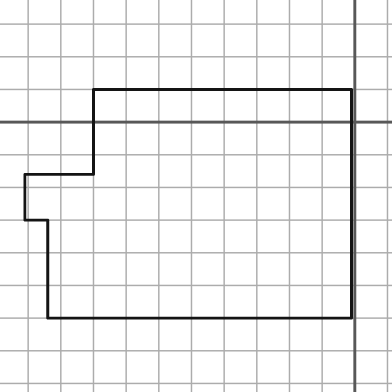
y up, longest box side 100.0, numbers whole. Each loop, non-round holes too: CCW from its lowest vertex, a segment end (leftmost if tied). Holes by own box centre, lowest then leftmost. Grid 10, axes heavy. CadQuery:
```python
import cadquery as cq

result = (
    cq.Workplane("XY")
    .moveTo(-94.0, -60.0)
    .lineTo(-1.0, -60.0)
    .lineTo(-1.0, 10.0)
    .lineTo(-80.0, 10.0)
    .lineTo(-80.0, -16.0)
    .lineTo(-101.0, -16.0)
    .lineTo(-101.0, -30.0)
    .lineTo(-94.0, -30.0)
    .close()
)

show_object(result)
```